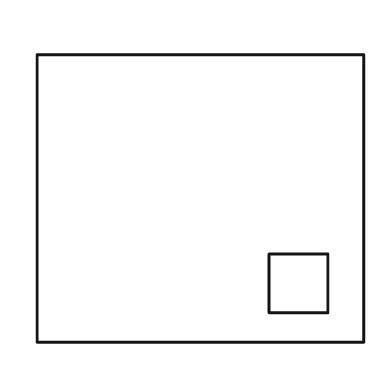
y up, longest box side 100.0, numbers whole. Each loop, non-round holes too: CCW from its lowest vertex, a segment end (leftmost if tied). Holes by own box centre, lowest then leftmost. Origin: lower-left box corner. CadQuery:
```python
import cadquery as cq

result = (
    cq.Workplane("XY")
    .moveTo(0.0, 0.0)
    .lineTo(100.0, 0.0)
    .lineTo(100.0, 88.0)
    .lineTo(0.0, 88.0)
    .close()
    .moveTo(71.0, 9.0)
    .lineTo(89.0, 9.0)
    .lineTo(89.0, 27.0)
    .lineTo(71.0, 27.0)
    .close()
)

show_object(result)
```